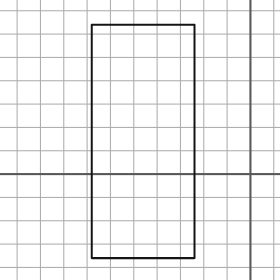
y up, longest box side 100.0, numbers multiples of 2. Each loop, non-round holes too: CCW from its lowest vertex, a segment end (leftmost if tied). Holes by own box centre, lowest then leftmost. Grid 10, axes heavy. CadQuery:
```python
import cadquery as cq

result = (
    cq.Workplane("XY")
    .moveTo(-68.0, -36.0)
    .lineTo(-24.0, -36.0)
    .lineTo(-24.0, 64.0)
    .lineTo(-68.0, 64.0)
    .close()
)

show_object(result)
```